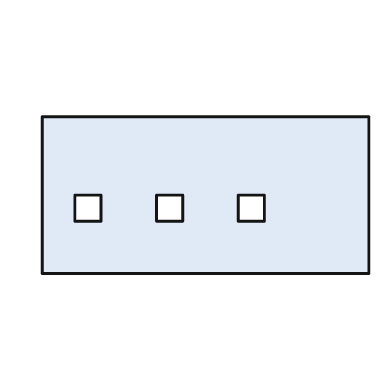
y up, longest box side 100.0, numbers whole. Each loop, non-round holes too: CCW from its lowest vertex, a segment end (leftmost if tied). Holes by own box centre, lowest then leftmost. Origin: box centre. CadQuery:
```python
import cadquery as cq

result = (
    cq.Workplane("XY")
    .moveTo(-50.0, -24.0)
    .lineTo(50.0, -24.0)
    .lineTo(50.0, 24.0)
    .lineTo(-50.0, 24.0)
    .close()
    .moveTo(-40.0, -8.0)
    .lineTo(-32.0, -8.0)
    .lineTo(-32.0, 0.0)
    .lineTo(-40.0, 0.0)
    .close()
    .moveTo(-15.0, -8.0)
    .lineTo(-7.0, -8.0)
    .lineTo(-7.0, 0.0)
    .lineTo(-15.0, 0.0)
    .close()
    .moveTo(10.0, -8.0)
    .lineTo(18.0, -8.0)
    .lineTo(18.0, 0.0)
    .lineTo(10.0, 0.0)
    .close()
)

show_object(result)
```